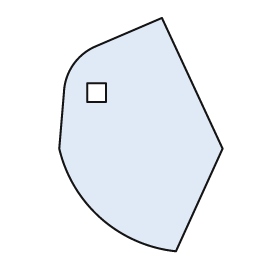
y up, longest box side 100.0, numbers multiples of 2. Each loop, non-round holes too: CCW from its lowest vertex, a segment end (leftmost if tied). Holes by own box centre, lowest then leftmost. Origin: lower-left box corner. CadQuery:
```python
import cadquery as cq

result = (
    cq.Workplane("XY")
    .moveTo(50.0, 0.0)
    .lineTo(70.0, 44.0)
    .lineTo(44.0, 100.0)
    .lineTo(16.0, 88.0)
    .threePointArc((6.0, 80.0), (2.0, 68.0))
    .lineTo(0.0, 44.0)
    .threePointArc((18.0, 14.0), (50.0, 0.0))
    .close()
    .moveTo(12.0, 64.0)
    .lineTo(20.0, 64.0)
    .lineTo(20.0, 72.0)
    .lineTo(12.0, 72.0)
    .close()
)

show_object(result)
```